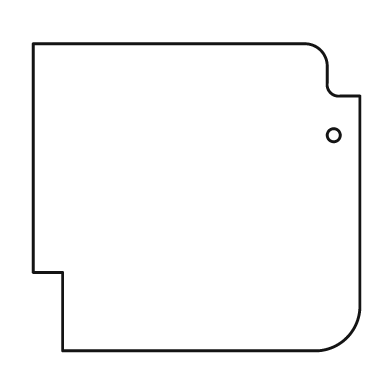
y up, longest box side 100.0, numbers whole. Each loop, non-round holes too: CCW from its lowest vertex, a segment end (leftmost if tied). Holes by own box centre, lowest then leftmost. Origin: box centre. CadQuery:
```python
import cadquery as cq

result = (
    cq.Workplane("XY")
    .moveTo(-41.0, -47.0)
    .lineTo(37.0, -47.0)
    .threePointArc((46.0, -43.0), (50.0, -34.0))
    .lineTo(50.0, 31.0)
    .lineTo(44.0, 31.0)
    .threePointArc((41.0, 32.0), (40.0, 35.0))
    .lineTo(40.0, 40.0)
    .threePointArc((38.0, 45.0), (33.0, 47.0))
    .lineTo(-50.0, 47.0)
    .lineTo(-50.0, -23.0)
    .lineTo(-41.0, -23.0)
    .close()
    .moveTo(42.0, 19.0)
    .circle(2.0)
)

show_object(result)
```